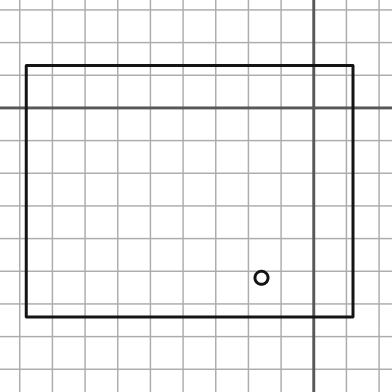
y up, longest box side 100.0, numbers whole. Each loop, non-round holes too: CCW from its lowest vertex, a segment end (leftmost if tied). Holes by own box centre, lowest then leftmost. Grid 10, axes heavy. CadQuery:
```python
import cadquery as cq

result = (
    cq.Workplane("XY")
    .moveTo(-88.0, -64.0)
    .lineTo(12.0, -64.0)
    .lineTo(12.0, 13.0)
    .lineTo(-88.0, 13.0)
    .close()
    .moveTo(-16.0, -52.0)
    .circle(2.0)
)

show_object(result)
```